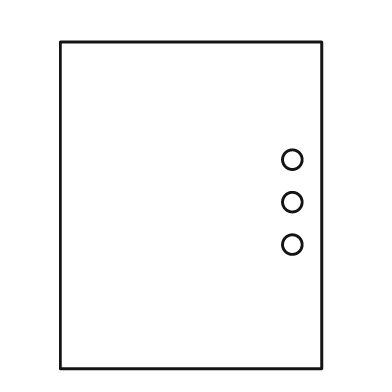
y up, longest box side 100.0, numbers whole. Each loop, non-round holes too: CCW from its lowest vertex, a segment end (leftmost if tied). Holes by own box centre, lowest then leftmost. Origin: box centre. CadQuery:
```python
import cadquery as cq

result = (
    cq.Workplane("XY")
    .moveTo(-40.0, -50.0)
    .lineTo(40.0, -50.0)
    .lineTo(40.0, 50.0)
    .lineTo(-40.0, 50.0)
    .close()
    .moveTo(31.0, -12.0)
    .circle(3.0)
    .moveTo(31.0, 1.0)
    .circle(3.0)
    .moveTo(31.0, 14.0)
    .circle(3.0)
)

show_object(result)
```